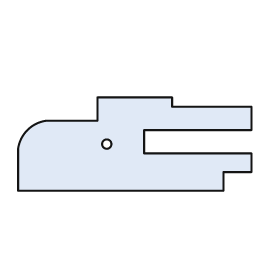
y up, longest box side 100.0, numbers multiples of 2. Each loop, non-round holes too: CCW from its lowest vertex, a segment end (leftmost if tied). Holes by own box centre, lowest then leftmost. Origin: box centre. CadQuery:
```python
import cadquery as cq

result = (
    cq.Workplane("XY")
    .moveTo(-50.0, -20.0)
    .lineTo(38.0, -20.0)
    .lineTo(38.0, -12.0)
    .lineTo(50.0, -12.0)
    .lineTo(50.0, -4.0)
    .lineTo(4.0, -4.0)
    .lineTo(4.0, 6.0)
    .lineTo(50.0, 6.0)
    .lineTo(50.0, 16.0)
    .lineTo(16.0, 16.0)
    .lineTo(16.0, 20.0)
    .lineTo(-16.0, 20.0)
    .lineTo(-16.0, 10.0)
    .lineTo(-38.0, 10.0)
    .threePointArc((-46.0, 6.0), (-50.0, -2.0))
    .close()
    .moveTo(-12.0, 0.0)
    .circle(2.0)
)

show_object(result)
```